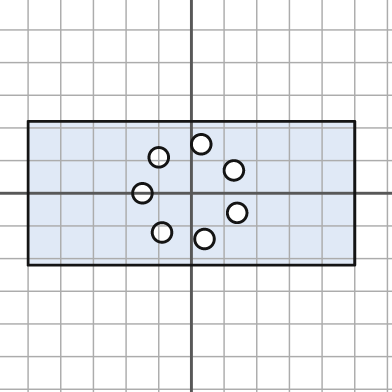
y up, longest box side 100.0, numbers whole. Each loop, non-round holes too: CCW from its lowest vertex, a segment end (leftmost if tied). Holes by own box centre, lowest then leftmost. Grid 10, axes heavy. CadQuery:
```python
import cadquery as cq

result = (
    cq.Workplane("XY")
    .moveTo(-50.0, -22.0)
    .lineTo(50.0, -22.0)
    .lineTo(50.0, 22.0)
    .lineTo(-50.0, 22.0)
    .close()
    .moveTo(4.0, -14.0)
    .circle(3.0)
    .moveTo(-9.0, -12.0)
    .circle(3.0)
    .moveTo(14.0, -6.0)
    .circle(3.0)
    .moveTo(-15.0, 0.0)
    .circle(3.0)
    .moveTo(13.0, 7.0)
    .circle(3.0)
    .moveTo(-10.0, 11.0)
    .circle(3.0)
    .moveTo(3.0, 15.0)
    .circle(3.0)
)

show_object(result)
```